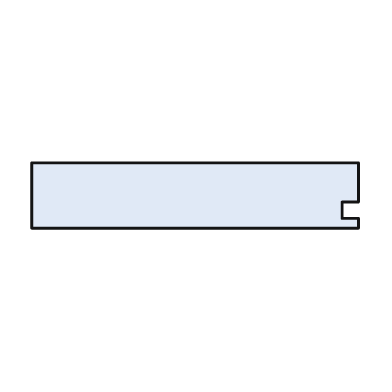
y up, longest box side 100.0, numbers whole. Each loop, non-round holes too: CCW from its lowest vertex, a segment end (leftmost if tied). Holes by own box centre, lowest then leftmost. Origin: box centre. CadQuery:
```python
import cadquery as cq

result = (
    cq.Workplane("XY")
    .moveTo(-50.0, -10.0)
    .lineTo(50.0, -10.0)
    .lineTo(50.0, -7.0)
    .lineTo(45.0, -7.0)
    .lineTo(45.0, -2.0)
    .lineTo(50.0, -2.0)
    .lineTo(50.0, 10.0)
    .lineTo(-50.0, 10.0)
    .close()
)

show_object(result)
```